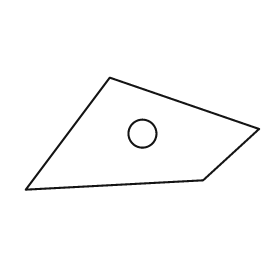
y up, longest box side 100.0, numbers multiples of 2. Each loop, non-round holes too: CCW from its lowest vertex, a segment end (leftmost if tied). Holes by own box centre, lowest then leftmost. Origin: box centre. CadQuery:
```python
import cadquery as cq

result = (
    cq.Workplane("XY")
    .moveTo(-50.0, -24.0)
    .lineTo(26.0, -20.0)
    .lineTo(50.0, 2.0)
    .lineTo(-14.0, 24.0)
    .close()
    .moveTo(0.0, 0.0)
    .circle(6.0)
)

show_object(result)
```